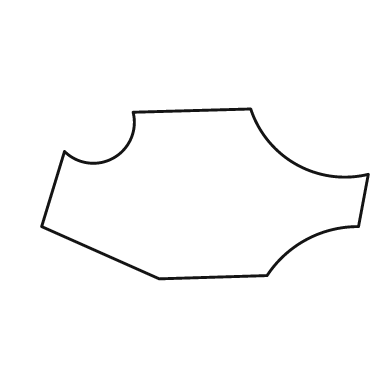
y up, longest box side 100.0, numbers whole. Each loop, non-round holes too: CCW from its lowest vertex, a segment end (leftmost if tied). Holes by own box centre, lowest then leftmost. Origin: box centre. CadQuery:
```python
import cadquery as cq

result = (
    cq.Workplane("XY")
    .moveTo(-14.0, -26.0)
    .lineTo(19.0, -25.0)
    .threePointArc((31.0, -14.0), (47.0, -10.0))
    .lineTo(50.0, 6.0)
    .threePointArc((28.0, 9.0), (14.0, 26.0))
    .lineTo(-22.0, 25.0)
    .threePointArc((-28.0, 11.0), (-43.0, 13.0))
    .lineTo(-50.0, -10.0)
    .close()
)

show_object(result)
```